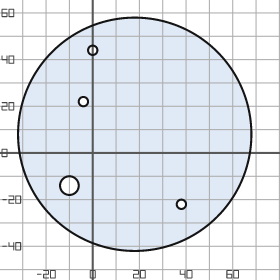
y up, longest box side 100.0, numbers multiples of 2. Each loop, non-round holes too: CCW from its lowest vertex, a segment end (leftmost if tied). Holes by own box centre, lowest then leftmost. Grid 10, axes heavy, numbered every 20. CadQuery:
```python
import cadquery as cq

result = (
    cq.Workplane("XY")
    .moveTo(18.0, 8.0)
    .circle(50.0)
    .moveTo(38.0, -22.0)
    .circle(2.0)
    .moveTo(-10.0, -14.0)
    .circle(4.0)
    .moveTo(-4.0, 22.0)
    .circle(2.0)
    .moveTo(0.0, 44.0)
    .circle(2.0)
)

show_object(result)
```